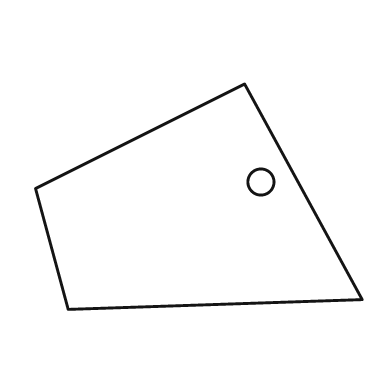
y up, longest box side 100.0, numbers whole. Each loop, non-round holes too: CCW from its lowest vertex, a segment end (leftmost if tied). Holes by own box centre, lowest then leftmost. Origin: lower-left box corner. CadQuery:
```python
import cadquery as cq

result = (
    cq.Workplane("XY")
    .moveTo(10.0, 0.0)
    .lineTo(100.0, 3.0)
    .lineTo(64.0, 69.0)
    .lineTo(0.0, 37.0)
    .close()
    .moveTo(69.0, 39.0)
    .circle(4.0)
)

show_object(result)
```